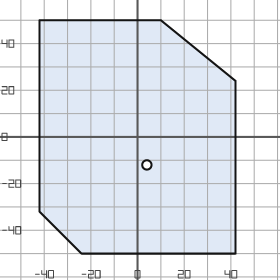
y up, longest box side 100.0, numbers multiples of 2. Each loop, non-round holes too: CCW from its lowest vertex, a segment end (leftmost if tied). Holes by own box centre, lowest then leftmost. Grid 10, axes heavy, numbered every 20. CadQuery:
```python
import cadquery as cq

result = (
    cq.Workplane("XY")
    .moveTo(-24.0, -50.0)
    .lineTo(42.0, -50.0)
    .lineTo(42.0, 24.0)
    .lineTo(10.0, 50.0)
    .lineTo(-42.0, 50.0)
    .lineTo(-42.0, -32.0)
    .close()
    .moveTo(4.0, -12.0)
    .circle(2.0)
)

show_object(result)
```